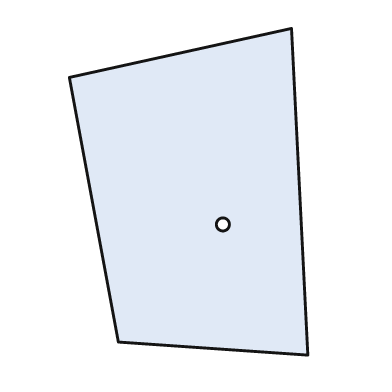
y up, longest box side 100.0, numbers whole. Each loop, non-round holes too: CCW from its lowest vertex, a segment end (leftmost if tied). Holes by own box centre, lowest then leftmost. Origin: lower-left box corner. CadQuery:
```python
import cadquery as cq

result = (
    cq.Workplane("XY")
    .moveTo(73.0, 0.0)
    .lineTo(68.0, 100.0)
    .lineTo(0.0, 85.0)
    .lineTo(15.0, 4.0)
    .close()
    .moveTo(47.0, 40.0)
    .circle(2.0)
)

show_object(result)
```